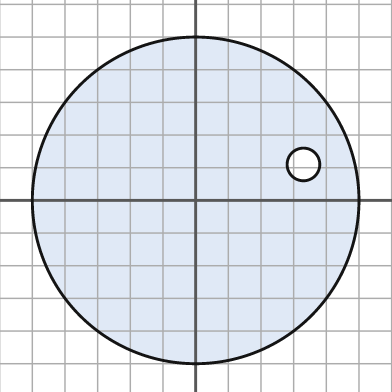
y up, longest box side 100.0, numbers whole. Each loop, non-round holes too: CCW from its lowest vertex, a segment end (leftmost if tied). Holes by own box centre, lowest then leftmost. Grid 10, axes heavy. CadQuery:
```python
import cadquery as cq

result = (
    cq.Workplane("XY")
    .moveTo(0.0, 0.0)
    .circle(50.0)
    .moveTo(33.0, 11.0)
    .circle(5.0)
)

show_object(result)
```